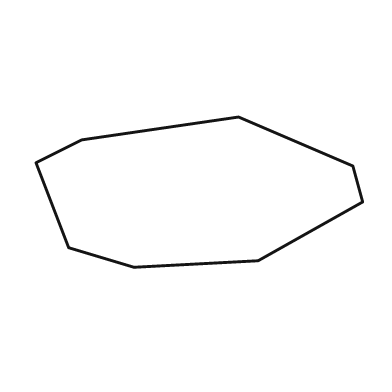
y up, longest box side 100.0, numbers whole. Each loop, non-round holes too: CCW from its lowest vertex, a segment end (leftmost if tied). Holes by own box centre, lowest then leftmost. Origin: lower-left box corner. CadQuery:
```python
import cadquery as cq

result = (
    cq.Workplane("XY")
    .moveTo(30.0, 0.0)
    .lineTo(68.0, 2.0)
    .lineTo(100.0, 20.0)
    .lineTo(97.0, 31.0)
    .lineTo(62.0, 46.0)
    .lineTo(14.0, 39.0)
    .lineTo(0.0, 32.0)
    .lineTo(10.0, 6.0)
    .close()
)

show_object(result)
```